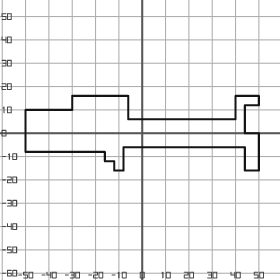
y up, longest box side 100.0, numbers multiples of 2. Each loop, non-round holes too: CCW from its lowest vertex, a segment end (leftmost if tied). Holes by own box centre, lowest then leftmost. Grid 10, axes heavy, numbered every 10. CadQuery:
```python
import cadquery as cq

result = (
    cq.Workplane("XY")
    .moveTo(-12.0, -16.0)
    .lineTo(-8.0, -16.0)
    .lineTo(-8.0, -6.0)
    .lineTo(44.0, -6.0)
    .lineTo(44.0, -16.0)
    .lineTo(50.0, -16.0)
    .lineTo(50.0, 0.0)
    .lineTo(44.0, 0.0)
    .lineTo(44.0, 12.0)
    .lineTo(50.0, 12.0)
    .lineTo(50.0, 16.0)
    .lineTo(40.0, 16.0)
    .lineTo(40.0, 6.0)
    .lineTo(-6.0, 6.0)
    .lineTo(-6.0, 16.0)
    .lineTo(-30.0, 16.0)
    .lineTo(-30.0, 10.0)
    .lineTo(-50.0, 10.0)
    .lineTo(-50.0, -8.0)
    .lineTo(-16.0, -8.0)
    .lineTo(-16.0, -12.0)
    .lineTo(-12.0, -12.0)
    .close()
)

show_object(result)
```